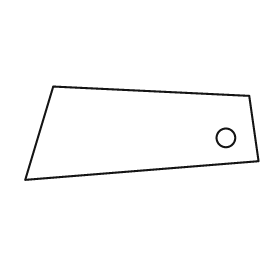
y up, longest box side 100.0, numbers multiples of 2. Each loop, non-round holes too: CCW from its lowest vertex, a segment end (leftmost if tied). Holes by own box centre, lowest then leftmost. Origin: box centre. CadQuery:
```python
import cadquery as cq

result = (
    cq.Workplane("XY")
    .moveTo(-50.0, -20.0)
    .lineTo(50.0, -12.0)
    .lineTo(46.0, 16.0)
    .lineTo(-38.0, 20.0)
    .close()
    .moveTo(36.0, -2.0)
    .circle(4.0)
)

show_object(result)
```